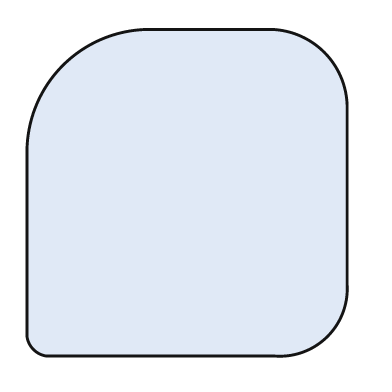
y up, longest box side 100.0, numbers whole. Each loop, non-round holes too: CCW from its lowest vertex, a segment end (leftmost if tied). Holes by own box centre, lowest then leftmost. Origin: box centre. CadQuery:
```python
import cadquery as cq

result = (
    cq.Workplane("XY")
    .moveTo(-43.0, -50.0)
    .lineTo(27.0, -50.0)
    .threePointArc((43.0, -44.0), (49.0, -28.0))
    .lineTo(49.0, 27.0)
    .threePointArc((42.0, 43.0), (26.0, 50.0))
    .lineTo(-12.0, 50.0)
    .threePointArc((-38.0, 39.0), (-49.0, 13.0))
    .lineTo(-49.0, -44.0)
    .threePointArc((-47.0, -48.0), (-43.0, -50.0))
    .close()
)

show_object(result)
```